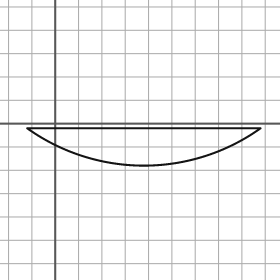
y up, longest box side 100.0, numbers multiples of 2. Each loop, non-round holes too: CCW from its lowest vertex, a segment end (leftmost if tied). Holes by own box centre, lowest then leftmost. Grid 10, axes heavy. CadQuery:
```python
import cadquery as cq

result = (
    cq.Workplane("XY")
    .moveTo(-12.0, -2.0)
    .threePointArc((38.0, -18.0), (88.0, -2.0))
    .close()
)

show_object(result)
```